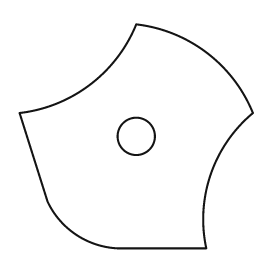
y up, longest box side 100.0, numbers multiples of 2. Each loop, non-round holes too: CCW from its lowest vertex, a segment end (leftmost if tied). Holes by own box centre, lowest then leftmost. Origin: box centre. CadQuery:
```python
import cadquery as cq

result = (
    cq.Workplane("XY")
    .moveTo(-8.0, -48.0)
    .lineTo(30.0, -48.0)
    .threePointArc((32.0, -16.0), (50.0, 10.0))
    .threePointArc((30.0, 36.0), (0.0, 48.0))
    .threePointArc((-20.0, 22.0), (-50.0, 10.0))
    .lineTo(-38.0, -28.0)
    .threePointArc((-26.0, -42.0), (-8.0, -48.0))
    .close()
    .moveTo(0.0, 0.0)
    .circle(8.0)
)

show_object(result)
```